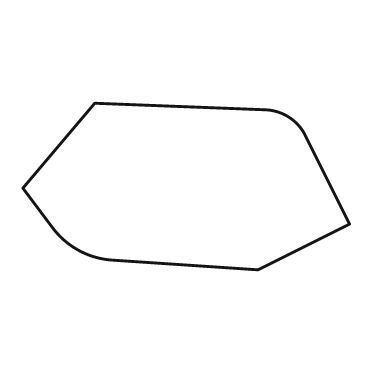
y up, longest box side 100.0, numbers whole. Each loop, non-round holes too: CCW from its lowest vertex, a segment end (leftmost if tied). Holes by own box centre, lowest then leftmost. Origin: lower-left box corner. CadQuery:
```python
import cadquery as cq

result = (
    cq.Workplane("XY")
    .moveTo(72.0, 0.0)
    .lineTo(100.0, 14.0)
    .lineTo(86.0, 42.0)
    .threePointArc((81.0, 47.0), (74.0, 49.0))
    .lineTo(22.0, 51.0)
    .lineTo(0.0, 25.0)
    .lineTo(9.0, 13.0)
    .threePointArc((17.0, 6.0), (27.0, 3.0))
    .close()
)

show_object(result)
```